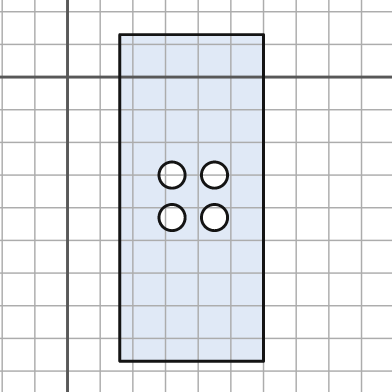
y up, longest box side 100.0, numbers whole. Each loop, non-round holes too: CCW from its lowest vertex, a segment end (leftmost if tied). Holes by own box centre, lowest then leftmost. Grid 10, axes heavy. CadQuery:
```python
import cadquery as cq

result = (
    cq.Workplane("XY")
    .moveTo(16.0, -87.0)
    .lineTo(60.0, -87.0)
    .lineTo(60.0, 13.0)
    .lineTo(16.0, 13.0)
    .close()
    .moveTo(32.0, -43.0)
    .circle(4.0)
    .moveTo(45.0, -43.0)
    .circle(4.0)
    .moveTo(32.0, -30.0)
    .circle(4.0)
    .moveTo(45.0, -30.0)
    .circle(4.0)
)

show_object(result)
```